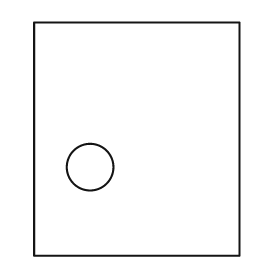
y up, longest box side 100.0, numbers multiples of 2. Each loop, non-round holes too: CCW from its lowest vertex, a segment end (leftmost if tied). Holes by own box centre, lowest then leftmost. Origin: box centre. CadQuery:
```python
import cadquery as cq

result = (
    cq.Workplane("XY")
    .moveTo(-44.0, -50.0)
    .lineTo(44.0, -50.0)
    .lineTo(44.0, 50.0)
    .lineTo(-44.0, 50.0)
    .close()
    .moveTo(-20.0, -12.0)
    .circle(10.0)
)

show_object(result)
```